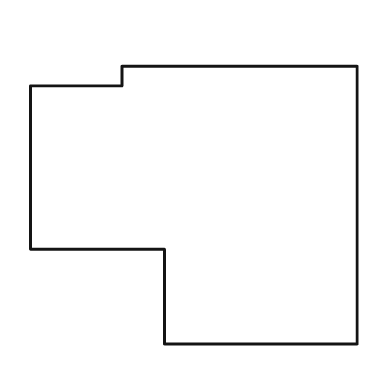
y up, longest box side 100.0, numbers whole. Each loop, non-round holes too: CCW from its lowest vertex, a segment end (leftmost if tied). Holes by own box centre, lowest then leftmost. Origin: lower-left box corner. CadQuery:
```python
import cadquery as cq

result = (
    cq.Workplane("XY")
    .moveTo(41.0, 0.0)
    .lineTo(100.0, 0.0)
    .lineTo(100.0, 85.0)
    .lineTo(28.0, 85.0)
    .lineTo(28.0, 79.0)
    .lineTo(0.0, 79.0)
    .lineTo(0.0, 29.0)
    .lineTo(41.0, 29.0)
    .close()
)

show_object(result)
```